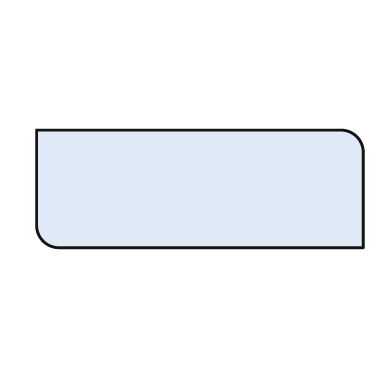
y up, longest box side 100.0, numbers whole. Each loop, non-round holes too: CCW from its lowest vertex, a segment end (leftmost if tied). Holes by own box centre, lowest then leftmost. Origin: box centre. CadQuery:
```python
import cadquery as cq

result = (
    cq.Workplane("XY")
    .moveTo(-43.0, -18.0)
    .lineTo(50.0, -18.0)
    .lineTo(50.0, 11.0)
    .threePointArc((48.0, 16.0), (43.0, 18.0))
    .lineTo(-50.0, 18.0)
    .lineTo(-50.0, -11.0)
    .threePointArc((-48.0, -16.0), (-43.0, -18.0))
    .close()
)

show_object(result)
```